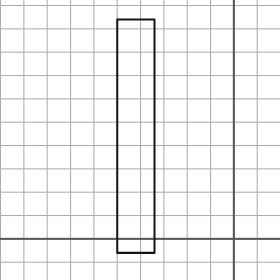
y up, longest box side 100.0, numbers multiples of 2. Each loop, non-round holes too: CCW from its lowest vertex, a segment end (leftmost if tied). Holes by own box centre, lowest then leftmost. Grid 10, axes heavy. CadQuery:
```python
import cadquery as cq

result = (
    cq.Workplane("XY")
    .moveTo(-50.0, -6.0)
    .lineTo(-34.0, -6.0)
    .lineTo(-34.0, 94.0)
    .lineTo(-50.0, 94.0)
    .close()
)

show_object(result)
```